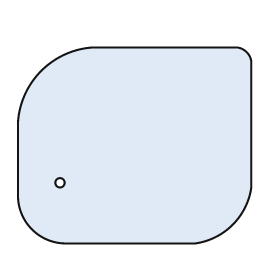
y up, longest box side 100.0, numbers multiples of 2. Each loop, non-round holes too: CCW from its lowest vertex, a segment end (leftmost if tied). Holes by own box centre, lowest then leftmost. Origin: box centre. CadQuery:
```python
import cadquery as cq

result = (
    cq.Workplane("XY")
    .moveTo(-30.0, -42.0)
    .lineTo(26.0, -42.0)
    .threePointArc((42.0, -34.0), (50.0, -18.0))
    .lineTo(50.0, 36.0)
    .threePointArc((48.0, 40.0), (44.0, 42.0))
    .lineTo(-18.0, 42.0)
    .threePointArc((-40.0, 32.0), (-50.0, 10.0))
    .lineTo(-50.0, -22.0)
    .threePointArc((-44.0, -36.0), (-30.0, -42.0))
    .close()
    .moveTo(-32.0, -16.0)
    .circle(2.0)
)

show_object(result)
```